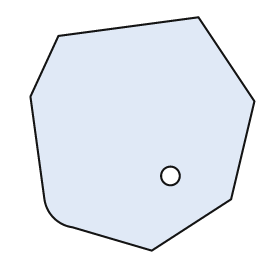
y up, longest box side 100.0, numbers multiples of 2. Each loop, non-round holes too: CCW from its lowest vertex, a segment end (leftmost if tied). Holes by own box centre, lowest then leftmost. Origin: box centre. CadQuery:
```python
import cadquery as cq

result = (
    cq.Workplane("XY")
    .moveTo(4.0, -50.0)
    .lineTo(38.0, -28.0)
    .lineTo(48.0, 14.0)
    .lineTo(24.0, 50.0)
    .lineTo(-36.0, 42.0)
    .lineTo(-48.0, 16.0)
    .lineTo(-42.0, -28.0)
    .threePointArc((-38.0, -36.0), (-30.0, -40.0))
    .close()
    .moveTo(12.0, -18.0)
    .circle(4.0)
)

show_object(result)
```